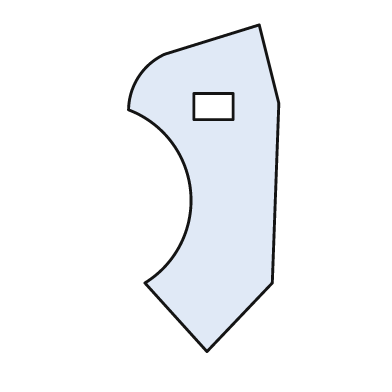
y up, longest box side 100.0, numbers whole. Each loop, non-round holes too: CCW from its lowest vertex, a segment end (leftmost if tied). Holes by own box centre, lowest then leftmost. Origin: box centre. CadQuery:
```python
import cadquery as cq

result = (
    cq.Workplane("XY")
    .moveTo(1.0, -50.0)
    .lineTo(21.0, -29.0)
    .lineTo(23.0, 26.0)
    .lineTo(17.0, 50.0)
    .lineTo(-12.0, 41.0)
    .threePointArc((-20.0, 34.0), (-23.0, 24.0))
    .threePointArc((-4.0, -1.0), (-18.0, -29.0))
    .close()
    .moveTo(-3.0, 21.0)
    .lineTo(9.0, 21.0)
    .lineTo(9.0, 29.0)
    .lineTo(-3.0, 29.0)
    .close()
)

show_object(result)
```